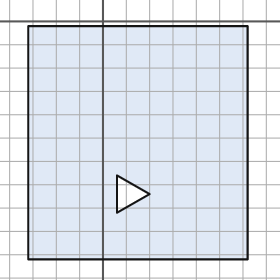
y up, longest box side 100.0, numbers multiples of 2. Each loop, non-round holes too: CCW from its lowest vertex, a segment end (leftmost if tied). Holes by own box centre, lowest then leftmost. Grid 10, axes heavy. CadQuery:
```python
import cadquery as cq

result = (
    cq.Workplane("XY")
    .moveTo(-32.0, -102.0)
    .lineTo(62.0, -102.0)
    .lineTo(62.0, -2.0)
    .lineTo(-32.0, -2.0)
    .close()
    .moveTo(6.0, -82.0)
    .lineTo(20.0, -74.0)
    .lineTo(6.0, -66.0)
    .close()
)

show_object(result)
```